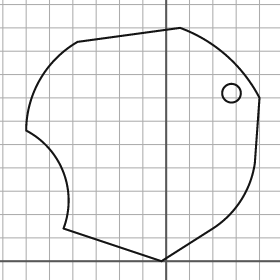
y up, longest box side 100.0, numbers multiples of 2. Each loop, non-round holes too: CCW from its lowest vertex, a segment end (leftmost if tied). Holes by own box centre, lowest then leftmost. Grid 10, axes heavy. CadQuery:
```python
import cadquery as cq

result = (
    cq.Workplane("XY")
    .moveTo(-2.0, 0.0)
    .lineTo(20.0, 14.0)
    .threePointArc((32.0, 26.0), (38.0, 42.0))
    .lineTo(40.0, 70.0)
    .threePointArc((26.0, 88.0), (6.0, 100.0))
    .lineTo(-38.0, 94.0)
    .threePointArc((-54.0, 78.0), (-60.0, 56.0))
    .threePointArc((-44.0, 38.0), (-44.0, 14.0))
    .close()
    .moveTo(28.0, 72.0)
    .circle(4.0)
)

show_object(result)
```